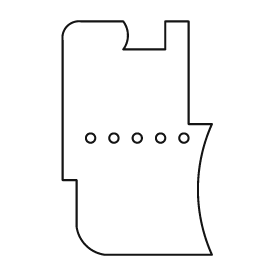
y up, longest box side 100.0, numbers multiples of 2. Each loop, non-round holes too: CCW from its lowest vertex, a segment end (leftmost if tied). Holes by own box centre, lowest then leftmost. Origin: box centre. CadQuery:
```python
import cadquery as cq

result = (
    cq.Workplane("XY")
    .moveTo(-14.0, -50.0)
    .lineTo(32.0, -50.0)
    .threePointArc((26.0, -22.0), (32.0, 6.0))
    .lineTo(22.0, 6.0)
    .lineTo(22.0, 50.0)
    .lineTo(12.0, 50.0)
    .lineTo(12.0, 38.0)
    .lineTo(-6.0, 38.0)
    .threePointArc((-4.0, 44.0), (-6.0, 50.0))
    .lineTo(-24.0, 50.0)
    .threePointArc((-30.0, 48.0), (-32.0, 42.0))
    .lineTo(-32.0, -18.0)
    .lineTo(-26.0, -18.0)
    .lineTo(-26.0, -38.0)
    .threePointArc((-22.0, -46.0), (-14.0, -50.0))
    .close()
    .moveTo(-20.0, 0.0)
    .circle(2.0)
    .moveTo(-10.0, 0.0)
    .circle(2.0)
    .moveTo(0.0, 0.0)
    .circle(2.0)
    .moveTo(10.0, 0.0)
    .circle(2.0)
    .moveTo(20.0, 0.0)
    .circle(2.0)
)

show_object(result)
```